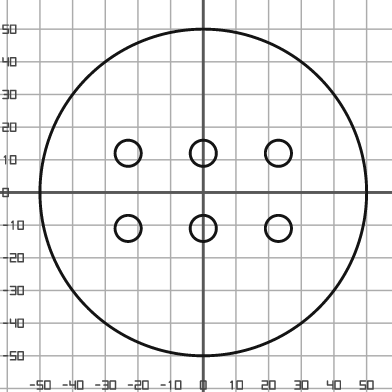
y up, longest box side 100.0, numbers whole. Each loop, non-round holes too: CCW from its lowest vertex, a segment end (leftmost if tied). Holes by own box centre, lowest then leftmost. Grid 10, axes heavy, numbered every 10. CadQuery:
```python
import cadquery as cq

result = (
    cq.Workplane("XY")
    .moveTo(0.0, 0.0)
    .circle(50.0)
    .moveTo(-23.0, -11.0)
    .circle(4.0)
    .moveTo(0.0, -11.0)
    .circle(4.0)
    .moveTo(23.0, -11.0)
    .circle(4.0)
    .moveTo(-23.0, 12.0)
    .circle(4.0)
    .moveTo(0.0, 12.0)
    .circle(4.0)
    .moveTo(23.0, 12.0)
    .circle(4.0)
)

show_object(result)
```